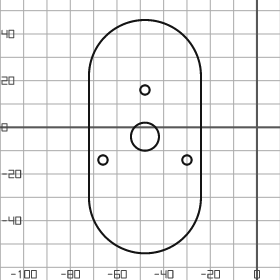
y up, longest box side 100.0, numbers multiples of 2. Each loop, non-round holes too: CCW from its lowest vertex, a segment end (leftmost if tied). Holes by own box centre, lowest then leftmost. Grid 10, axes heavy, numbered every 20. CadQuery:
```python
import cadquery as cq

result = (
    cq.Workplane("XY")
    .moveTo(-72.0, -30.0)
    .threePointArc((-48.0, -54.0), (-24.0, -30.0))
    .lineTo(-24.0, 22.0)
    .threePointArc((-48.0, 46.0), (-72.0, 22.0))
    .close()
    .moveTo(-66.0, -14.0)
    .circle(2.0)
    .moveTo(-30.0, -14.0)
    .circle(2.0)
    .moveTo(-48.0, -4.0)
    .circle(6.0)
    .moveTo(-48.0, 16.0)
    .circle(2.0)
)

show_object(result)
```